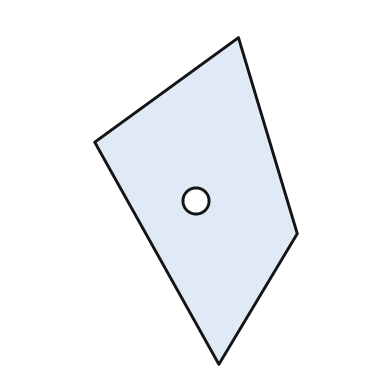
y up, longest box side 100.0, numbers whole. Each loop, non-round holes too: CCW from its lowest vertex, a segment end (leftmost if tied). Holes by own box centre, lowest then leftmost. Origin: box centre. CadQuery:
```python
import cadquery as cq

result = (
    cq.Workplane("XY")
    .moveTo(7.0, -50.0)
    .lineTo(31.0, -10.0)
    .lineTo(13.0, 50.0)
    .lineTo(-31.0, 18.0)
    .close()
    .moveTo(0.0, 0.0)
    .circle(4.0)
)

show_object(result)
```